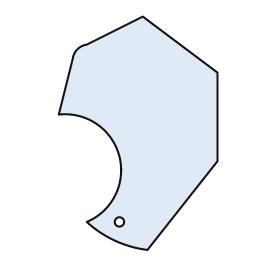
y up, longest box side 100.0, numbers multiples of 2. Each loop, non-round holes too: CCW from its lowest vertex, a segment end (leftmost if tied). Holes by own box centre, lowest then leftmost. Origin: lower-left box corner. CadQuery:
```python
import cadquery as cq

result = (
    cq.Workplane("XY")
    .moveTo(38.0, 0.0)
    .lineTo(68.0, 38.0)
    .lineTo(68.0, 76.0)
    .lineTo(36.0, 100.0)
    .lineTo(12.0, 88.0)
    .threePointArc((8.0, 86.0), (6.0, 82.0))
    .lineTo(0.0, 58.0)
    .threePointArc((26.0, 40.0), (12.0, 12.0))
    .threePointArc((24.0, 4.0), (38.0, 0.0))
    .close()
    .moveTo(26.0, 12.0)
    .circle(2.0)
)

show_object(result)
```